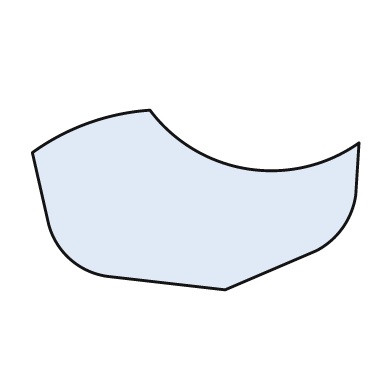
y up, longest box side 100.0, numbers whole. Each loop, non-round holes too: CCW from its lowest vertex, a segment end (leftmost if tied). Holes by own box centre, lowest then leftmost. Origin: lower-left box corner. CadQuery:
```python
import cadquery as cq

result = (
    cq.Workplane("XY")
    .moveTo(59.0, 0.0)
    .lineTo(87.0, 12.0)
    .threePointArc((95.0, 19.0), (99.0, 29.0))
    .lineTo(100.0, 45.0)
    .threePointArc((66.0, 37.0), (36.0, 55.0))
    .threePointArc((17.0, 51.0), (0.0, 42.0))
    .lineTo(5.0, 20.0)
    .threePointArc((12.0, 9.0), (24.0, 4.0))
    .close()
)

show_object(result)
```